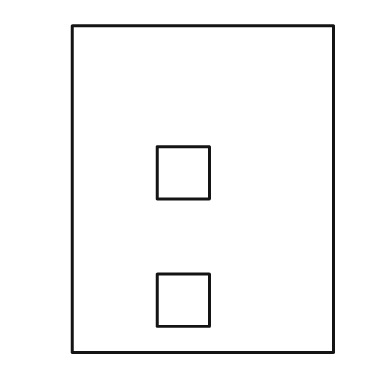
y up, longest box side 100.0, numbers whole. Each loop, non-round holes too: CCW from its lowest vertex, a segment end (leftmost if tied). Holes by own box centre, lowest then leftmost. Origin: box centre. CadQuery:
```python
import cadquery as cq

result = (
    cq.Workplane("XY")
    .moveTo(-40.0, -50.0)
    .lineTo(40.0, -50.0)
    .lineTo(40.0, 50.0)
    .lineTo(-40.0, 50.0)
    .close()
    .moveTo(-14.0, -42.0)
    .lineTo(2.0, -42.0)
    .lineTo(2.0, -26.0)
    .lineTo(-14.0, -26.0)
    .close()
    .moveTo(-14.0, -3.0)
    .lineTo(2.0, -3.0)
    .lineTo(2.0, 13.0)
    .lineTo(-14.0, 13.0)
    .close()
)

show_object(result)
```